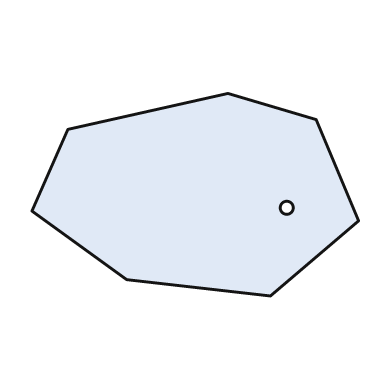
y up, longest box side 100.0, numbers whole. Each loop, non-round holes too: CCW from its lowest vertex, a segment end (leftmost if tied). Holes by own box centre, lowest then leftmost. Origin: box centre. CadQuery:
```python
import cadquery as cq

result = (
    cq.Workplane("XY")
    .moveTo(23.0, -31.0)
    .lineTo(50.0, -8.0)
    .lineTo(37.0, 23.0)
    .lineTo(10.0, 31.0)
    .lineTo(-39.0, 20.0)
    .lineTo(-50.0, -5.0)
    .lineTo(-21.0, -26.0)
    .close()
    .moveTo(28.0, -4.0)
    .circle(2.0)
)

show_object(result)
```